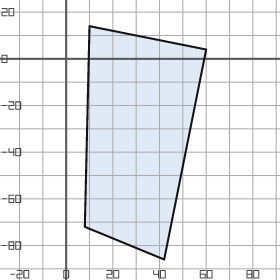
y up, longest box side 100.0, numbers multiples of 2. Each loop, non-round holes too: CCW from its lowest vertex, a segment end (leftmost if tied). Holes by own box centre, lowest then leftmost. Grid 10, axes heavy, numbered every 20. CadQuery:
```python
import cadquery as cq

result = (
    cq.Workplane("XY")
    .moveTo(42.0, -86.0)
    .lineTo(60.0, 4.0)
    .lineTo(10.0, 14.0)
    .lineTo(8.0, -72.0)
    .close()
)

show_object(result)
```